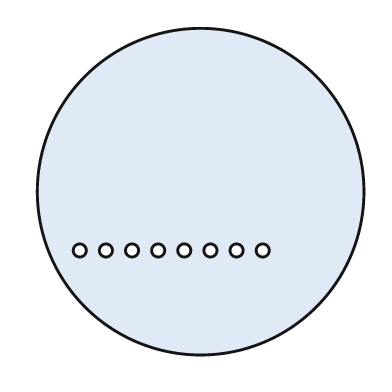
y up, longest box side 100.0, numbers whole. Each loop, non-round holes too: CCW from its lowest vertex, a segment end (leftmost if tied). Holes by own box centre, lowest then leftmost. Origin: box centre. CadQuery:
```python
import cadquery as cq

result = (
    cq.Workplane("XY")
    .moveTo(0.0, 0.0)
    .circle(50.0)
    .moveTo(-37.0, -18.0)
    .circle(2.0)
    .moveTo(-29.0, -18.0)
    .circle(2.0)
    .moveTo(-21.0, -18.0)
    .circle(2.0)
    .moveTo(-13.0, -18.0)
    .circle(2.0)
    .moveTo(-5.0, -18.0)
    .circle(2.0)
    .moveTo(3.0, -18.0)
    .circle(2.0)
    .moveTo(11.0, -18.0)
    .circle(2.0)
    .moveTo(19.0, -18.0)
    .circle(2.0)
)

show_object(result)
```